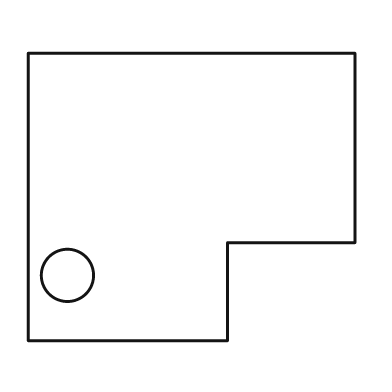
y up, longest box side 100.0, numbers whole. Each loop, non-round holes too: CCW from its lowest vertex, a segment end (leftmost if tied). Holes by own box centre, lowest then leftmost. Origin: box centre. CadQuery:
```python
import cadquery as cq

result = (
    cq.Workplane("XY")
    .moveTo(-50.0, -44.0)
    .lineTo(11.0, -44.0)
    .lineTo(11.0, -14.0)
    .lineTo(50.0, -14.0)
    .lineTo(50.0, 44.0)
    .lineTo(-50.0, 44.0)
    .close()
    .moveTo(-38.0, -24.0)
    .circle(8.0)
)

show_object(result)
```